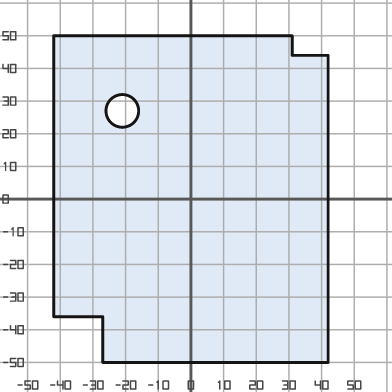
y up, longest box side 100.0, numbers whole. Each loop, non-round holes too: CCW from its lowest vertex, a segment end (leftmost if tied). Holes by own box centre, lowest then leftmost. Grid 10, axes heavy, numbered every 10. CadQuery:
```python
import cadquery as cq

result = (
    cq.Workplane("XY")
    .moveTo(-27.0, -50.0)
    .lineTo(42.0, -50.0)
    .lineTo(42.0, 44.0)
    .lineTo(31.0, 44.0)
    .lineTo(31.0, 50.0)
    .lineTo(-42.0, 50.0)
    .lineTo(-42.0, -36.0)
    .lineTo(-27.0, -36.0)
    .close()
    .moveTo(-21.0, 27.0)
    .circle(5.0)
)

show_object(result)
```